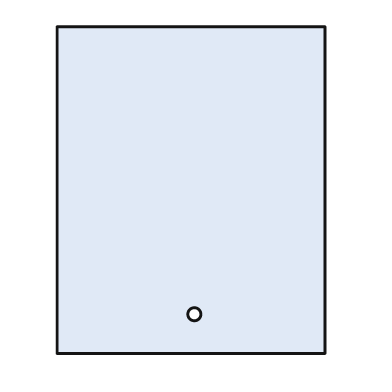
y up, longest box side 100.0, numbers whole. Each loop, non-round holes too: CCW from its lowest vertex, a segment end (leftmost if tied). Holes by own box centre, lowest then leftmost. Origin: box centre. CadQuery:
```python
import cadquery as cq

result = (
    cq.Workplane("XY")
    .moveTo(-41.0, -50.0)
    .lineTo(41.0, -50.0)
    .lineTo(41.0, 50.0)
    .lineTo(-41.0, 50.0)
    .close()
    .moveTo(1.0, -38.0)
    .circle(2.0)
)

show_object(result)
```